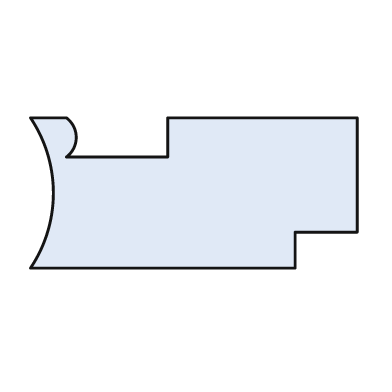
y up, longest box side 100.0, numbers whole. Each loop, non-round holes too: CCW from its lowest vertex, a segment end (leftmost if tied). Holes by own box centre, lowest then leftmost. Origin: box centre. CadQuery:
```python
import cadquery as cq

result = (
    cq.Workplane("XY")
    .moveTo(-50.0, -23.0)
    .lineTo(31.0, -23.0)
    .lineTo(31.0, -12.0)
    .lineTo(50.0, -12.0)
    .lineTo(50.0, 23.0)
    .lineTo(-8.0, 23.0)
    .lineTo(-8.0, 11.0)
    .lineTo(-39.0, 11.0)
    .threePointArc((-36.0, 17.0), (-39.0, 23.0))
    .lineTo(-50.0, 23.0)
    .threePointArc((-43.0, 0.0), (-50.0, -23.0))
    .close()
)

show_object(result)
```